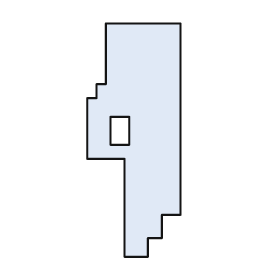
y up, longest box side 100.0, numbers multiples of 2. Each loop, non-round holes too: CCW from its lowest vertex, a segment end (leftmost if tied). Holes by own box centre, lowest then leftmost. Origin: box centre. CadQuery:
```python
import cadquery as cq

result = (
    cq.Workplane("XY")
    .moveTo(-4.0, -50.0)
    .lineTo(6.0, -50.0)
    .lineTo(6.0, -42.0)
    .lineTo(12.0, -42.0)
    .lineTo(12.0, -32.0)
    .lineTo(20.0, -32.0)
    .lineTo(20.0, 50.0)
    .lineTo(-12.0, 50.0)
    .lineTo(-12.0, 24.0)
    .lineTo(-16.0, 24.0)
    .lineTo(-16.0, 18.0)
    .lineTo(-20.0, 18.0)
    .lineTo(-20.0, -8.0)
    .lineTo(-4.0, -8.0)
    .close()
    .moveTo(-10.0, -2.0)
    .lineTo(-2.0, -2.0)
    .lineTo(-2.0, 10.0)
    .lineTo(-10.0, 10.0)
    .close()
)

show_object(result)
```